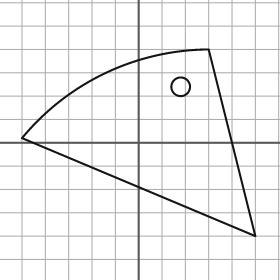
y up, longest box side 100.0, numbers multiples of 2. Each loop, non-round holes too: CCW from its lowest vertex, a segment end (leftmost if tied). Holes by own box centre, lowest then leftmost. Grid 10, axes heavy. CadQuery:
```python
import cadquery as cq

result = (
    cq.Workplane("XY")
    .moveTo(50.0, -40.0)
    .lineTo(30.0, 40.0)
    .threePointArc((-14.0, 30.0), (-50.0, 2.0))
    .close()
    .moveTo(18.0, 24.0)
    .circle(4.0)
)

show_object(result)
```